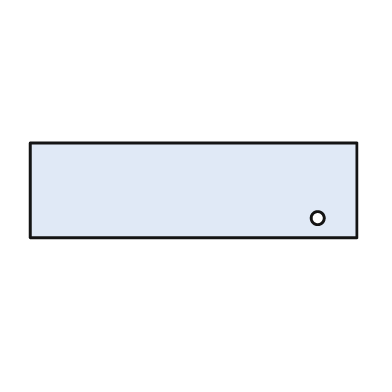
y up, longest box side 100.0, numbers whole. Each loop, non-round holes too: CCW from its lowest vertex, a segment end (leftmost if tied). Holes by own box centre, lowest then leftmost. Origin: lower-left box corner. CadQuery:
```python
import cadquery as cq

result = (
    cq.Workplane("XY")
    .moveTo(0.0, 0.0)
    .lineTo(100.0, 0.0)
    .lineTo(100.0, 29.0)
    .lineTo(0.0, 29.0)
    .close()
    .moveTo(88.0, 6.0)
    .circle(2.0)
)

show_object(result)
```